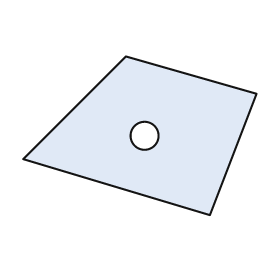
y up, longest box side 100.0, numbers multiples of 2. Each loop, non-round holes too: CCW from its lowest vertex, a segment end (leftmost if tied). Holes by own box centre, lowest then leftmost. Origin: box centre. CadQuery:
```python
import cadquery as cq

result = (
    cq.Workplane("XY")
    .moveTo(30.0, -34.0)
    .lineTo(50.0, 18.0)
    .lineTo(-6.0, 34.0)
    .lineTo(-50.0, -10.0)
    .close()
    .moveTo(2.0, 0.0)
    .circle(6.0)
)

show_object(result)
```